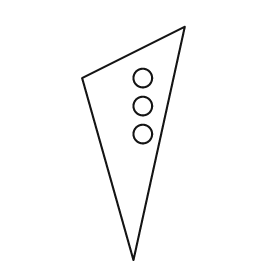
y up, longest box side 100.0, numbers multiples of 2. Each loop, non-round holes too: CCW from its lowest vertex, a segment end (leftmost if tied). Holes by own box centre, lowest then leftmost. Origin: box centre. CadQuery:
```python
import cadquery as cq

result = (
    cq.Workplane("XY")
    .moveTo(0.0, -50.0)
    .lineTo(22.0, 50.0)
    .lineTo(-22.0, 28.0)
    .close()
    .moveTo(4.0, 4.0)
    .circle(4.0)
    .moveTo(4.0, 16.0)
    .circle(4.0)
    .moveTo(4.0, 28.0)
    .circle(4.0)
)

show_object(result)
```